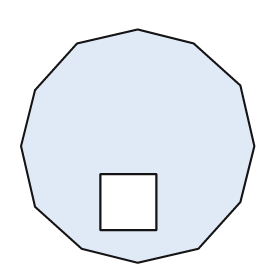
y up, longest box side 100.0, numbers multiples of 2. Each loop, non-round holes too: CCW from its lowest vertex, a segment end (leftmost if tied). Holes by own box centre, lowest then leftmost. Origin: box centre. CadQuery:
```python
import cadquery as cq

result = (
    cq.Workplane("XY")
    .moveTo(0.0, -50.0)
    .lineTo(26.0, -44.0)
    .lineTo(44.0, -24.0)
    .lineTo(50.0, 0.0)
    .lineTo(44.0, 26.0)
    .lineTo(24.0, 44.0)
    .lineTo(0.0, 50.0)
    .lineTo(-26.0, 44.0)
    .lineTo(-44.0, 24.0)
    .lineTo(-50.0, 0.0)
    .lineTo(-44.0, -26.0)
    .lineTo(-24.0, -44.0)
    .close()
    .moveTo(-16.0, -36.0)
    .lineTo(8.0, -36.0)
    .lineTo(8.0, -12.0)
    .lineTo(-16.0, -12.0)
    .close()
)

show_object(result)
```